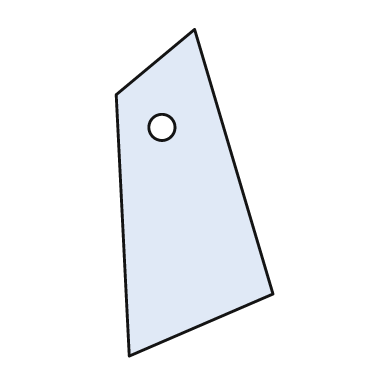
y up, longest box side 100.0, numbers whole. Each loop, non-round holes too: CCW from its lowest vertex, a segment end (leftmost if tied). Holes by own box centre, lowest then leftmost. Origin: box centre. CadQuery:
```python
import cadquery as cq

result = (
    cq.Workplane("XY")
    .moveTo(-20.0, -50.0)
    .lineTo(24.0, -31.0)
    .lineTo(0.0, 50.0)
    .lineTo(-24.0, 30.0)
    .close()
    .moveTo(-10.0, 20.0)
    .circle(4.0)
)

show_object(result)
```